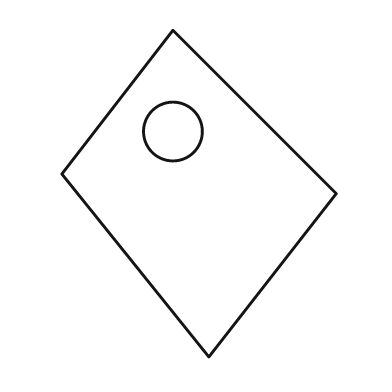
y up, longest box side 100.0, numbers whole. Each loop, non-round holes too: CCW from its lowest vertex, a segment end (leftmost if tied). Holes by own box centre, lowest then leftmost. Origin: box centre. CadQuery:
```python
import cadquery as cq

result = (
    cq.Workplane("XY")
    .moveTo(3.0, -50.0)
    .lineTo(42.0, 0.0)
    .lineTo(-8.0, 50.0)
    .lineTo(-42.0, 6.0)
    .close()
    .moveTo(-8.0, 19.0)
    .circle(9.0)
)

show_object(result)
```